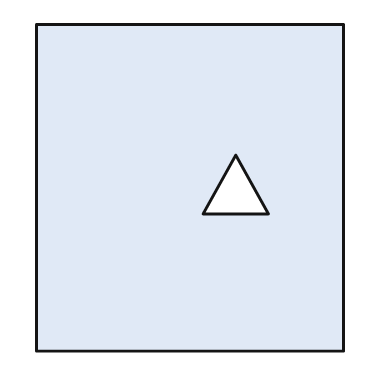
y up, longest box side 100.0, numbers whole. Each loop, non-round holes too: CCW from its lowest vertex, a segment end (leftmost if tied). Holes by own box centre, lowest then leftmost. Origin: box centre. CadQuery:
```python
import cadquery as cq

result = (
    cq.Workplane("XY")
    .moveTo(-47.0, -50.0)
    .lineTo(47.0, -50.0)
    .lineTo(47.0, 50.0)
    .lineTo(-47.0, 50.0)
    .close()
    .moveTo(4.0, -8.0)
    .lineTo(24.0, -8.0)
    .lineTo(14.0, 10.0)
    .close()
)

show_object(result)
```